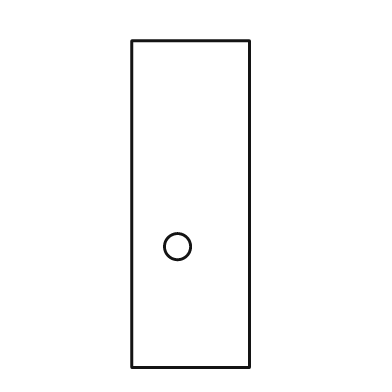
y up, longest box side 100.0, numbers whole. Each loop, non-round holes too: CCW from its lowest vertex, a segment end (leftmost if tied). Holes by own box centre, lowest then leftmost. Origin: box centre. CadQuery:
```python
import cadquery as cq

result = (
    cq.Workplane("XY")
    .moveTo(-18.0, -50.0)
    .lineTo(18.0, -50.0)
    .lineTo(18.0, 50.0)
    .lineTo(-18.0, 50.0)
    .close()
    .moveTo(-4.0, -13.0)
    .circle(4.0)
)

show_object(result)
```